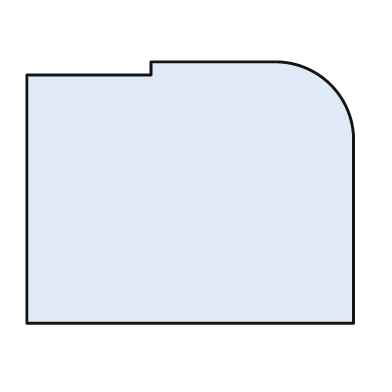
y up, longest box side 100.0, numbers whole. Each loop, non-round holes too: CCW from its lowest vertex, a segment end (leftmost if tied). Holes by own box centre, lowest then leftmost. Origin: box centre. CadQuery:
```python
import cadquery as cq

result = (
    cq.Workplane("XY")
    .moveTo(-50.0, -40.0)
    .lineTo(50.0, -40.0)
    .lineTo(50.0, 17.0)
    .threePointArc((43.0, 33.0), (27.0, 40.0))
    .lineTo(-12.0, 40.0)
    .lineTo(-12.0, 36.0)
    .lineTo(-50.0, 36.0)
    .close()
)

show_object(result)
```